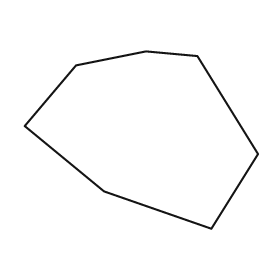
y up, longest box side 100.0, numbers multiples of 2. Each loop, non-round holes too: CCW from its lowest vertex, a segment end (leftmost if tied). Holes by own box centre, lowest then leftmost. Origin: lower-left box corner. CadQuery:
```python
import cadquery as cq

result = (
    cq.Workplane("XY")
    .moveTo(80.0, 0.0)
    .lineTo(100.0, 32.0)
    .lineTo(74.0, 74.0)
    .lineTo(52.0, 76.0)
    .lineTo(22.0, 70.0)
    .lineTo(0.0, 44.0)
    .lineTo(34.0, 16.0)
    .close()
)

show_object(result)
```